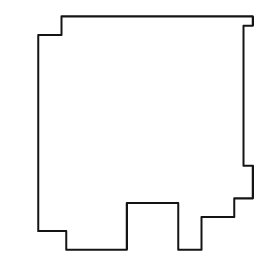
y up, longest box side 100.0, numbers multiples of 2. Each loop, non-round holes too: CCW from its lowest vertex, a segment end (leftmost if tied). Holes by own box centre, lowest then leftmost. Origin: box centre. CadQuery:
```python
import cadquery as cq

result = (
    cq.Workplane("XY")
    .moveTo(-34.0, -50.0)
    .lineTo(-8.0, -50.0)
    .lineTo(-8.0, -30.0)
    .lineTo(14.0, -30.0)
    .lineTo(14.0, -50.0)
    .lineTo(24.0, -50.0)
    .lineTo(24.0, -36.0)
    .lineTo(38.0, -36.0)
    .lineTo(38.0, -28.0)
    .lineTo(46.0, -28.0)
    .lineTo(46.0, -14.0)
    .lineTo(42.0, -14.0)
    .lineTo(42.0, 46.0)
    .lineTo(46.0, 46.0)
    .lineTo(46.0, 50.0)
    .lineTo(-36.0, 50.0)
    .lineTo(-36.0, 42.0)
    .lineTo(-46.0, 42.0)
    .lineTo(-46.0, -42.0)
    .lineTo(-34.0, -42.0)
    .close()
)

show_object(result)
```